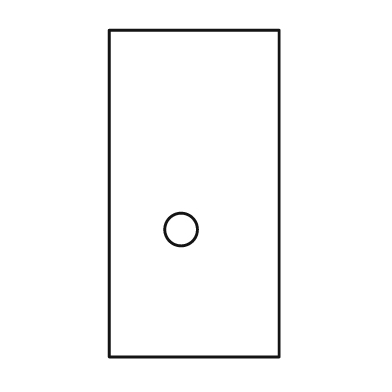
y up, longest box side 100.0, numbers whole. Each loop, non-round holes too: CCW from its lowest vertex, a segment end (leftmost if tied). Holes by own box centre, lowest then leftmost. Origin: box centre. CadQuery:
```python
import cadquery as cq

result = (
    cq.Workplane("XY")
    .moveTo(-26.0, -50.0)
    .lineTo(26.0, -50.0)
    .lineTo(26.0, 50.0)
    .lineTo(-26.0, 50.0)
    .close()
    .moveTo(-4.0, -11.0)
    .circle(5.0)
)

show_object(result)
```